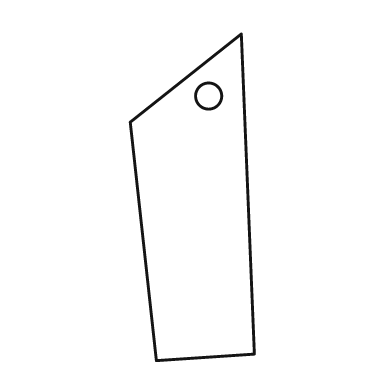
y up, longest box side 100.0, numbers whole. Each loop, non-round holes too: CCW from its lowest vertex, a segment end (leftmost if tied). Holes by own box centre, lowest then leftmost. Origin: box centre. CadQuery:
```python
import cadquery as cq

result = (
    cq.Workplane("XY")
    .moveTo(-11.0, -50.0)
    .lineTo(19.0, -48.0)
    .lineTo(15.0, 50.0)
    .lineTo(-19.0, 23.0)
    .close()
    .moveTo(5.0, 31.0)
    .circle(4.0)
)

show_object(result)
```